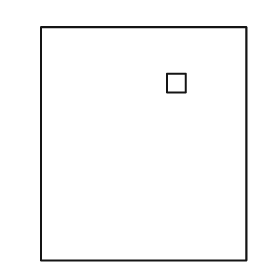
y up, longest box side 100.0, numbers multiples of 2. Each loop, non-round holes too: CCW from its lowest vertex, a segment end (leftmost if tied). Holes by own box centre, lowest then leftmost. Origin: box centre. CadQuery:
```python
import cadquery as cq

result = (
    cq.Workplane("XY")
    .moveTo(-44.0, -50.0)
    .lineTo(44.0, -50.0)
    .lineTo(44.0, 50.0)
    .lineTo(-44.0, 50.0)
    .close()
    .moveTo(10.0, 22.0)
    .lineTo(18.0, 22.0)
    .lineTo(18.0, 30.0)
    .lineTo(10.0, 30.0)
    .close()
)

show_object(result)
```